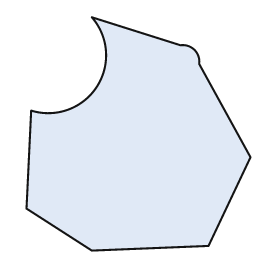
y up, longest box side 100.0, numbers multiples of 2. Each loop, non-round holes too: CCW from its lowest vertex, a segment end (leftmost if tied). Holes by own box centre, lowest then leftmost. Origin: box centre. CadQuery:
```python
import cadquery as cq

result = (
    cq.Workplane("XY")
    .moveTo(-20.0, -50.0)
    .lineTo(30.0, -48.0)
    .lineTo(48.0, -10.0)
    .lineTo(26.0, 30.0)
    .threePointArc((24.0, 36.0), (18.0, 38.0))
    .lineTo(-20.0, 50.0)
    .threePointArc((-18.0, 20.0), (-46.0, 10.0))
    .lineTo(-48.0, -32.0)
    .close()
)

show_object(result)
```